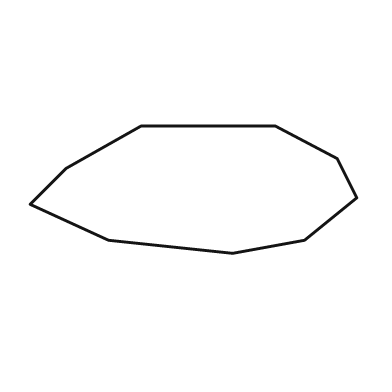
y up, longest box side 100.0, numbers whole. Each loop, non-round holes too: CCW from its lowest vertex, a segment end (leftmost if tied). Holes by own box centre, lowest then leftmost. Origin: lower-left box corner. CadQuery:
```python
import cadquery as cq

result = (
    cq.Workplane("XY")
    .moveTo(62.0, 0.0)
    .lineTo(84.0, 4.0)
    .lineTo(100.0, 17.0)
    .lineTo(94.0, 29.0)
    .lineTo(75.0, 39.0)
    .lineTo(34.0, 39.0)
    .lineTo(11.0, 26.0)
    .lineTo(0.0, 15.0)
    .lineTo(24.0, 4.0)
    .close()
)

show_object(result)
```